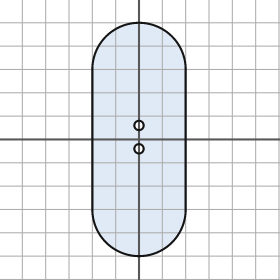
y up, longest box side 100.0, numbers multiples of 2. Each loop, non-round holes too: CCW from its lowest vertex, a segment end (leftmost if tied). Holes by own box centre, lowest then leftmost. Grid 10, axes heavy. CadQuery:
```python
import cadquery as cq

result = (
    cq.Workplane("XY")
    .moveTo(-20.0, -30.0)
    .threePointArc((0.0, -50.0), (20.0, -30.0))
    .lineTo(20.0, 30.0)
    .threePointArc((0.0, 50.0), (-20.0, 30.0))
    .close()
    .moveTo(0.0, -4.0)
    .circle(2.0)
    .moveTo(0.0, 6.0)
    .circle(2.0)
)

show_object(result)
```